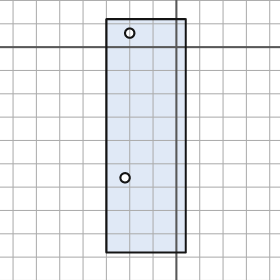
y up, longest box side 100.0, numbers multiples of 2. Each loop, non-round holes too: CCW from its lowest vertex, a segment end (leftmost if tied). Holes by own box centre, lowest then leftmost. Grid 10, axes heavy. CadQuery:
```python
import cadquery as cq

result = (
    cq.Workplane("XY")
    .moveTo(-30.0, -88.0)
    .lineTo(4.0, -88.0)
    .lineTo(4.0, 12.0)
    .lineTo(-30.0, 12.0)
    .close()
    .moveTo(-22.0, -56.0)
    .circle(2.0)
    .moveTo(-20.0, 6.0)
    .circle(2.0)
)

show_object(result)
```